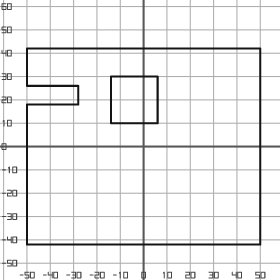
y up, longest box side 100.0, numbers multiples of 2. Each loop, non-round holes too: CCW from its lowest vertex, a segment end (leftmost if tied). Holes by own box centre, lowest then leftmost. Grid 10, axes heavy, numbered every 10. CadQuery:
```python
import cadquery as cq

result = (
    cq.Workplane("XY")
    .moveTo(-50.0, -42.0)
    .lineTo(50.0, -42.0)
    .lineTo(50.0, 42.0)
    .lineTo(-50.0, 42.0)
    .lineTo(-50.0, 26.0)
    .lineTo(-28.0, 26.0)
    .lineTo(-28.0, 18.0)
    .lineTo(-50.0, 18.0)
    .close()
    .moveTo(-14.0, 10.0)
    .lineTo(6.0, 10.0)
    .lineTo(6.0, 30.0)
    .lineTo(-14.0, 30.0)
    .close()
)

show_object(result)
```